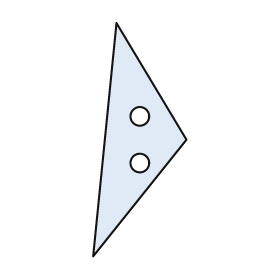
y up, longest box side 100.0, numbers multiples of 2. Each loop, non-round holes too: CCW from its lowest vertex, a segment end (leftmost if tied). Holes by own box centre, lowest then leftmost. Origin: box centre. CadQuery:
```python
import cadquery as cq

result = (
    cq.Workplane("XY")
    .moveTo(-20.0, -50.0)
    .lineTo(20.0, 0.0)
    .lineTo(-10.0, 50.0)
    .close()
    .moveTo(0.0, -10.0)
    .circle(4.0)
    .moveTo(0.0, 10.0)
    .circle(4.0)
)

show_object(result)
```